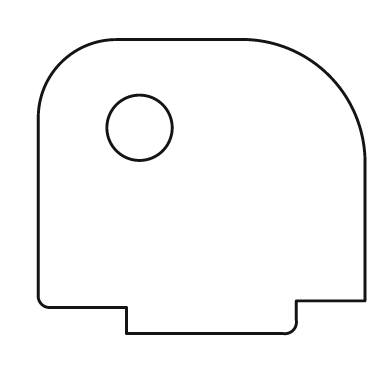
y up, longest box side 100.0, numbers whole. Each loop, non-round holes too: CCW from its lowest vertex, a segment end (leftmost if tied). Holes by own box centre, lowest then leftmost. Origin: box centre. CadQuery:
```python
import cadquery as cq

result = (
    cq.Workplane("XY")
    .moveTo(-23.0, -45.0)
    .lineTo(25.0, -45.0)
    .threePointArc((28.0, -44.0), (29.0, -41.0))
    .lineTo(29.0, -35.0)
    .lineTo(50.0, -35.0)
    .lineTo(50.0, 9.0)
    .threePointArc((39.0, 34.0), (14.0, 45.0))
    .lineTo(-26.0, 45.0)
    .threePointArc((-43.0, 38.0), (-50.0, 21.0))
    .lineTo(-50.0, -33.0)
    .threePointArc((-49.0, -36.0), (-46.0, -37.0))
    .lineTo(-23.0, -37.0)
    .close()
    .moveTo(-19.0, 18.0)
    .circle(10.0)
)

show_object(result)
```